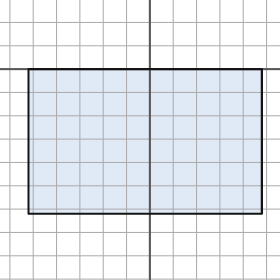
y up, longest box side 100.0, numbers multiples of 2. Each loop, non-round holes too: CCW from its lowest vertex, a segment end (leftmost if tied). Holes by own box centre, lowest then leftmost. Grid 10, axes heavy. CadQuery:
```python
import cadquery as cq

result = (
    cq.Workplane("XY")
    .moveTo(-52.0, -62.0)
    .lineTo(48.0, -62.0)
    .lineTo(48.0, 0.0)
    .lineTo(-52.0, 0.0)
    .close()
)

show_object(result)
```